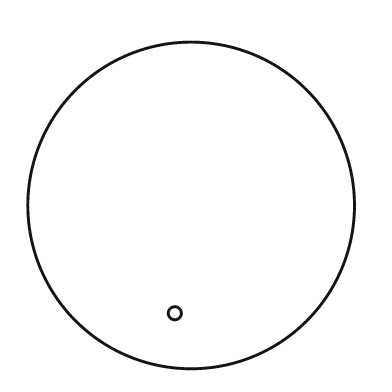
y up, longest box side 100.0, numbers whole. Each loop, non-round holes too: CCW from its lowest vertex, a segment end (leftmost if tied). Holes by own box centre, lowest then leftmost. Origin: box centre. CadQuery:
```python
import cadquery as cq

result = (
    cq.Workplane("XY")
    .moveTo(0.0, 0.0)
    .circle(50.0)
    .moveTo(-5.0, -33.0)
    .circle(2.0)
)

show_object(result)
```